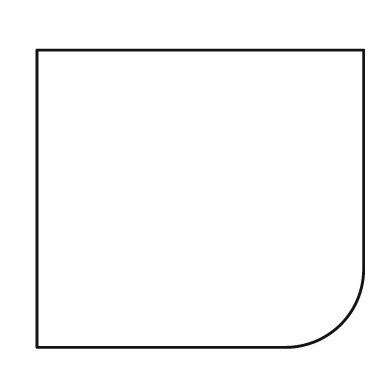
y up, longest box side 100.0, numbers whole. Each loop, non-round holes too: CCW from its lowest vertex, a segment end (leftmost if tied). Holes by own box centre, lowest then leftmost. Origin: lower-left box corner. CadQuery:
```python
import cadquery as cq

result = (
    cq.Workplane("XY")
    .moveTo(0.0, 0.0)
    .lineTo(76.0, 0.0)
    .threePointArc((93.0, 7.0), (100.0, 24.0))
    .lineTo(100.0, 91.0)
    .lineTo(0.0, 91.0)
    .close()
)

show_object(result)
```